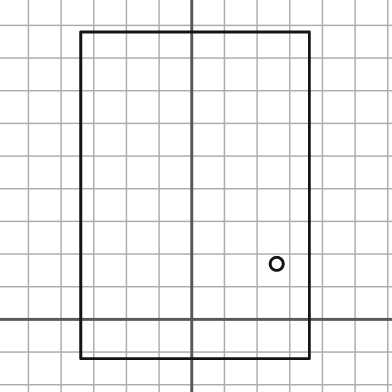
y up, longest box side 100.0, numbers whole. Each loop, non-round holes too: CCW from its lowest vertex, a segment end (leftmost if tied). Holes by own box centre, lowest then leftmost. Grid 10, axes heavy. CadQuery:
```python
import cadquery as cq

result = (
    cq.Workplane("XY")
    .moveTo(-34.0, -12.0)
    .lineTo(36.0, -12.0)
    .lineTo(36.0, 88.0)
    .lineTo(-34.0, 88.0)
    .close()
    .moveTo(26.0, 17.0)
    .circle(2.0)
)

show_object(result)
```